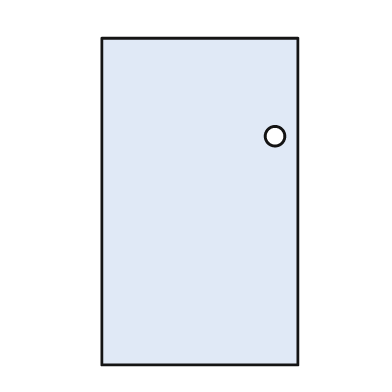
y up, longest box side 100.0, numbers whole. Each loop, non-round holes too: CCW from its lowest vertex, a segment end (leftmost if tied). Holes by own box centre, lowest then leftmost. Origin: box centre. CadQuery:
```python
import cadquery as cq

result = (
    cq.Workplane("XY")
    .moveTo(-30.0, -50.0)
    .lineTo(30.0, -50.0)
    .lineTo(30.0, 50.0)
    .lineTo(-30.0, 50.0)
    .close()
    .moveTo(23.0, 20.0)
    .circle(3.0)
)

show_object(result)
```